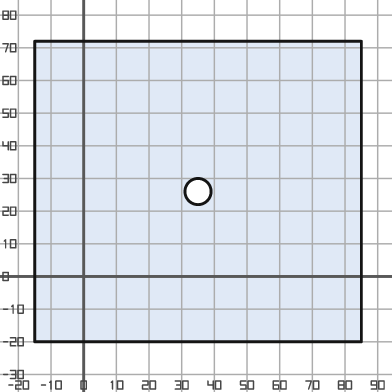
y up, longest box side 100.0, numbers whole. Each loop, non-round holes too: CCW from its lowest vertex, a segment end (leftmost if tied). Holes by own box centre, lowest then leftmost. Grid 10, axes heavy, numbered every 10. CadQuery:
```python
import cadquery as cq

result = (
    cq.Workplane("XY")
    .moveTo(-15.0, -20.0)
    .lineTo(85.0, -20.0)
    .lineTo(85.0, 72.0)
    .lineTo(-15.0, 72.0)
    .close()
    .moveTo(35.0, 26.0)
    .circle(4.0)
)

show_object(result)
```